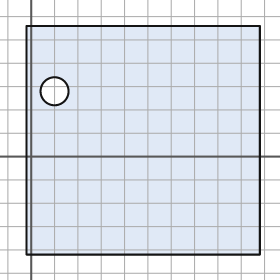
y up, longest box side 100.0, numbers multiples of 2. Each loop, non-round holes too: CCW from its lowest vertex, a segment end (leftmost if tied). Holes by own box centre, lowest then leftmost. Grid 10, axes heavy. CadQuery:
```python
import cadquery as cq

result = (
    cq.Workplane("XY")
    .moveTo(-2.0, -42.0)
    .lineTo(98.0, -42.0)
    .lineTo(98.0, 56.0)
    .lineTo(-2.0, 56.0)
    .close()
    .moveTo(10.0, 28.0)
    .circle(6.0)
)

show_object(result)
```